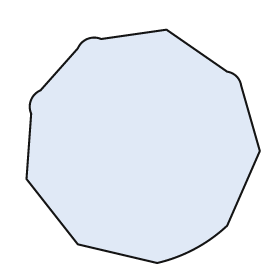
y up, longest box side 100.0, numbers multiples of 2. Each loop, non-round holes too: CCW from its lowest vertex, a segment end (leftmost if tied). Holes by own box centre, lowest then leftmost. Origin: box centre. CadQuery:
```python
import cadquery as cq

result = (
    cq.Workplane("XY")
    .moveTo(6.0, -50.0)
    .threePointArc((22.0, -44.0), (36.0, -34.0))
    .lineTo(50.0, -2.0)
    .lineTo(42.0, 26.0)
    .threePointArc((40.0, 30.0), (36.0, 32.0))
    .lineTo(10.0, 50.0)
    .lineTo(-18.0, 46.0)
    .threePointArc((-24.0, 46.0), (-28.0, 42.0))
    .lineTo(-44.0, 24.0)
    .threePointArc((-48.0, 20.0), (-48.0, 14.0))
    .lineTo(-50.0, -14.0)
    .lineTo(-28.0, -42.0)
    .close()
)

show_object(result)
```